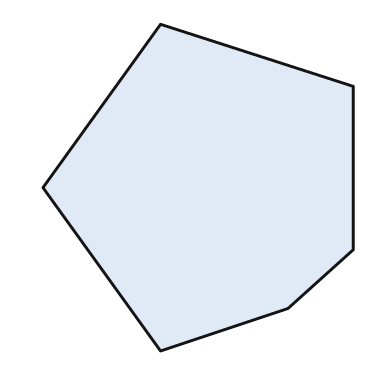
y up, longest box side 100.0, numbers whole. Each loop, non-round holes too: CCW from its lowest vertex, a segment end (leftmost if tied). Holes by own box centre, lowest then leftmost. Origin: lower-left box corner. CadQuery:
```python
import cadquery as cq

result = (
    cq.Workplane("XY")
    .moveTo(36.0, 0.0)
    .lineTo(75.0, 13.0)
    .lineTo(95.0, 31.0)
    .lineTo(95.0, 81.0)
    .lineTo(36.0, 100.0)
    .lineTo(0.0, 50.0)
    .close()
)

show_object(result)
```